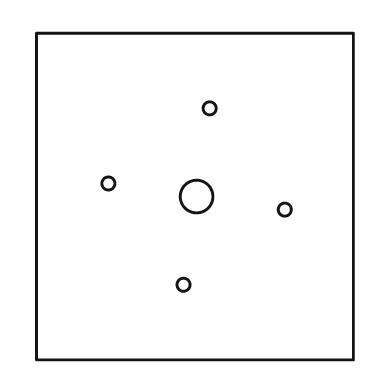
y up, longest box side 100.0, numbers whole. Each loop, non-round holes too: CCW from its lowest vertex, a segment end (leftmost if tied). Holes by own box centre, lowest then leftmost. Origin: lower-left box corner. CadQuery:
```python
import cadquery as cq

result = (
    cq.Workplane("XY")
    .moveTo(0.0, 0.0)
    .lineTo(97.0, 0.0)
    .lineTo(97.0, 100.0)
    .lineTo(0.0, 100.0)
    .close()
    .moveTo(45.0, 23.0)
    .circle(2.0)
    .moveTo(76.0, 46.0)
    .circle(2.0)
    .moveTo(49.0, 50.0)
    .circle(5.0)
    .moveTo(22.0, 54.0)
    .circle(2.0)
    .moveTo(53.0, 77.0)
    .circle(2.0)
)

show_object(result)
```